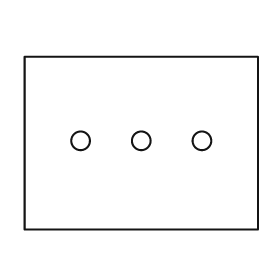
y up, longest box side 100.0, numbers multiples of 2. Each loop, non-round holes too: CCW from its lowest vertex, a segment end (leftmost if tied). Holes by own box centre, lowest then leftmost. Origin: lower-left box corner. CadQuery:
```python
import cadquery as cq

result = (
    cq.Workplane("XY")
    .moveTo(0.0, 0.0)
    .lineTo(100.0, 0.0)
    .lineTo(100.0, 74.0)
    .lineTo(0.0, 74.0)
    .close()
    .moveTo(24.0, 38.0)
    .circle(4.0)
    .moveTo(50.0, 38.0)
    .circle(4.0)
    .moveTo(76.0, 38.0)
    .circle(4.0)
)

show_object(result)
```